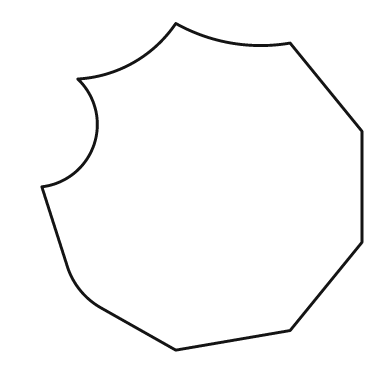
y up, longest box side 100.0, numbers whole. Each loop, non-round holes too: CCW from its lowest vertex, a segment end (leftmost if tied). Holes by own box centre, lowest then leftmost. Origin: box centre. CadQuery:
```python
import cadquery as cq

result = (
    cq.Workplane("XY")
    .moveTo(-8.0, -50.0)
    .lineTo(27.0, -44.0)
    .lineTo(49.0, -17.0)
    .lineTo(49.0, 17.0)
    .lineTo(27.0, 44.0)
    .threePointArc((9.0, 44.0), (-8.0, 50.0))
    .threePointArc((-21.0, 38.0), (-38.0, 33.0))
    .threePointArc((-33.0, 13.0), (-49.0, 0.0))
    .lineTo(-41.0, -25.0)
    .threePointArc((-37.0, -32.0), (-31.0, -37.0))
    .close()
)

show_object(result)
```